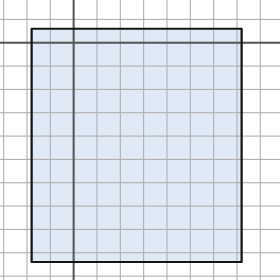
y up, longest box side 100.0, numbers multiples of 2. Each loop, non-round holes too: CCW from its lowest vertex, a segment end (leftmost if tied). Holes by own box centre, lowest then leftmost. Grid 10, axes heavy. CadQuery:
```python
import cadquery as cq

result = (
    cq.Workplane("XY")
    .moveTo(-18.0, -94.0)
    .lineTo(72.0, -94.0)
    .lineTo(72.0, 6.0)
    .lineTo(-18.0, 6.0)
    .close()
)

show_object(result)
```